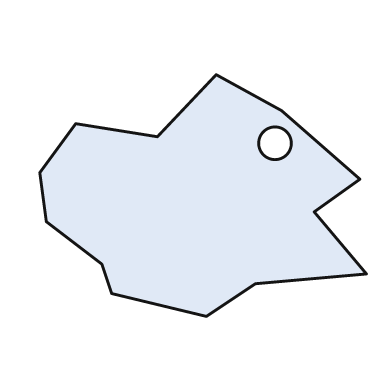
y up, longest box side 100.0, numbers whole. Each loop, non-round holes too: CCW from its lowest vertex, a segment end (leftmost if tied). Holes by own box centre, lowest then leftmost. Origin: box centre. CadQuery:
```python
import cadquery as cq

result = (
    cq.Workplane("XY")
    .moveTo(1.0, -37.0)
    .lineTo(16.0, -27.0)
    .lineTo(50.0, -24.0)
    .lineTo(34.0, -5.0)
    .lineTo(48.0, 5.0)
    .lineTo(24.0, 26.0)
    .lineTo(4.0, 37.0)
    .lineTo(-14.0, 18.0)
    .lineTo(-39.0, 22.0)
    .lineTo(-50.0, 7.0)
    .lineTo(-48.0, -8.0)
    .lineTo(-31.0, -21.0)
    .lineTo(-28.0, -30.0)
    .close()
    .moveTo(22.0, 16.0)
    .circle(5.0)
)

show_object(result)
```